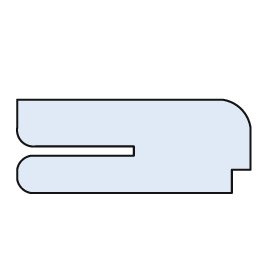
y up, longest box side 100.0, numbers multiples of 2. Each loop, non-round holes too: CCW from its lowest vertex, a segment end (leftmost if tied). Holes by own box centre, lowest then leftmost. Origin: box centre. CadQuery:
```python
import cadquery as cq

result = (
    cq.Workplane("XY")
    .moveTo(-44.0, -20.0)
    .lineTo(42.0, -20.0)
    .lineTo(42.0, -10.0)
    .lineTo(50.0, -10.0)
    .lineTo(50.0, 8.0)
    .threePointArc((46.0, 16.0), (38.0, 20.0))
    .lineTo(-50.0, 20.0)
    .lineTo(-50.0, 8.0)
    .threePointArc((-48.0, 2.0), (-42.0, 0.0))
    .lineTo(0.0, 0.0)
    .lineTo(0.0, -4.0)
    .lineTo(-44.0, -4.0)
    .threePointArc((-48.0, -6.0), (-50.0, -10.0))
    .lineTo(-50.0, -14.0)
    .threePointArc((-48.0, -18.0), (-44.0, -20.0))
    .close()
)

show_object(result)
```